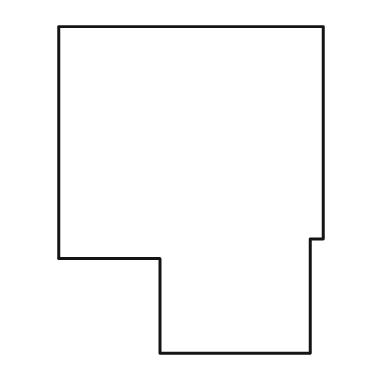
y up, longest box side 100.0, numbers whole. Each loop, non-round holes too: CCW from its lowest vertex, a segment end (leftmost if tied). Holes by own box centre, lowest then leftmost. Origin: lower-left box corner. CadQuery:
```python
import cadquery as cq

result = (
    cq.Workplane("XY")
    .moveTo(31.0, 0.0)
    .lineTo(77.0, 0.0)
    .lineTo(77.0, 35.0)
    .lineTo(81.0, 35.0)
    .lineTo(81.0, 100.0)
    .lineTo(0.0, 100.0)
    .lineTo(0.0, 29.0)
    .lineTo(31.0, 29.0)
    .close()
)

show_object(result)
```